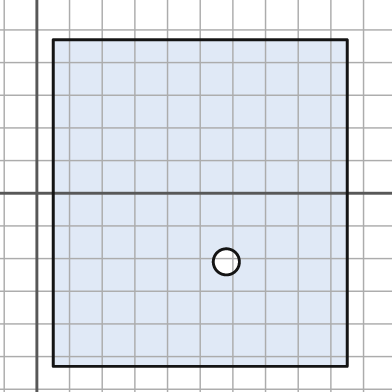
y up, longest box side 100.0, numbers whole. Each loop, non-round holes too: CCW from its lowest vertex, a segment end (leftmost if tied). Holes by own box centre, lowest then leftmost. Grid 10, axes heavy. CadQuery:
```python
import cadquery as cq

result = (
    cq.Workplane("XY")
    .moveTo(5.0, -53.0)
    .lineTo(95.0, -53.0)
    .lineTo(95.0, 47.0)
    .lineTo(5.0, 47.0)
    .close()
    .moveTo(58.0, -21.0)
    .circle(4.0)
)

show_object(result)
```